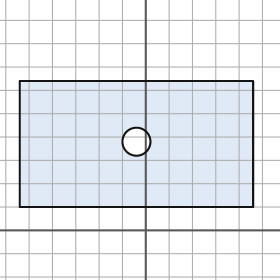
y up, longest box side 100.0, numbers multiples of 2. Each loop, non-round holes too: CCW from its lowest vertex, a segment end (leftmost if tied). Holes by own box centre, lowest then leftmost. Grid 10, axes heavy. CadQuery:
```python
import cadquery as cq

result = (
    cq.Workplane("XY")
    .moveTo(-54.0, 10.0)
    .lineTo(46.0, 10.0)
    .lineTo(46.0, 64.0)
    .lineTo(-54.0, 64.0)
    .close()
    .moveTo(-4.0, 38.0)
    .circle(6.0)
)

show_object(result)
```